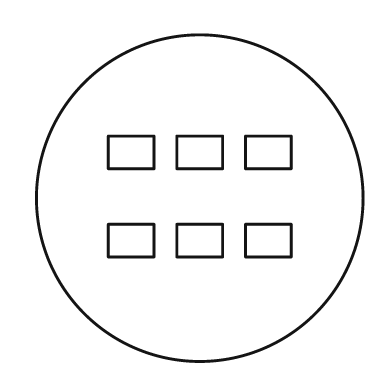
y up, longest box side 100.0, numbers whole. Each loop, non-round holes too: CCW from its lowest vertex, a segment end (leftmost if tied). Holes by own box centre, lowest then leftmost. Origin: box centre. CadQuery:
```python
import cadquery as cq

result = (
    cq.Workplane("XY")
    .moveTo(0.0, 0.0)
    .circle(50.0)
    .moveTo(-28.0, -18.0)
    .lineTo(-14.0, -18.0)
    .lineTo(-14.0, -8.0)
    .lineTo(-28.0, -8.0)
    .close()
    .moveTo(-7.0, -18.0)
    .lineTo(7.0, -18.0)
    .lineTo(7.0, -8.0)
    .lineTo(-7.0, -8.0)
    .close()
    .moveTo(14.0, -18.0)
    .lineTo(28.0, -18.0)
    .lineTo(28.0, -8.0)
    .lineTo(14.0, -8.0)
    .close()
    .moveTo(-28.0, 9.0)
    .lineTo(-14.0, 9.0)
    .lineTo(-14.0, 19.0)
    .lineTo(-28.0, 19.0)
    .close()
    .moveTo(-7.0, 9.0)
    .lineTo(7.0, 9.0)
    .lineTo(7.0, 19.0)
    .lineTo(-7.0, 19.0)
    .close()
    .moveTo(14.0, 9.0)
    .lineTo(28.0, 9.0)
    .lineTo(28.0, 19.0)
    .lineTo(14.0, 19.0)
    .close()
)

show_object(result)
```